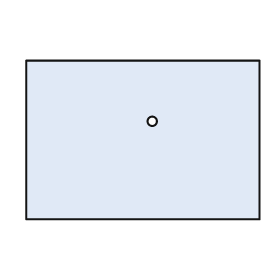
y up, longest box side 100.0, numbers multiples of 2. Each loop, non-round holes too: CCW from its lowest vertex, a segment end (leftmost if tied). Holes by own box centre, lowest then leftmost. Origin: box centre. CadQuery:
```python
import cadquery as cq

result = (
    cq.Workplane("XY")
    .moveTo(-50.0, -34.0)
    .lineTo(50.0, -34.0)
    .lineTo(50.0, 34.0)
    .lineTo(-50.0, 34.0)
    .close()
    .moveTo(4.0, 8.0)
    .circle(2.0)
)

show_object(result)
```